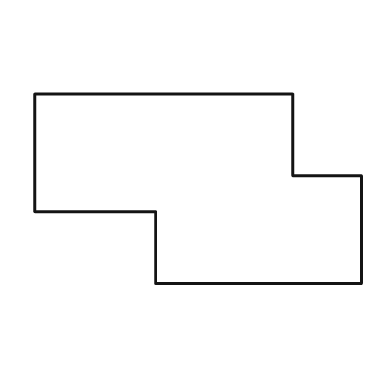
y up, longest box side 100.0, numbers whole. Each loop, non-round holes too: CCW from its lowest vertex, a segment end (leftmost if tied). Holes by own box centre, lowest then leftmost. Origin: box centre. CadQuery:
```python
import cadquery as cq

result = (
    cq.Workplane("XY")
    .moveTo(-13.0, -29.0)
    .lineTo(50.0, -29.0)
    .lineTo(50.0, 4.0)
    .lineTo(29.0, 4.0)
    .lineTo(29.0, 29.0)
    .lineTo(-50.0, 29.0)
    .lineTo(-50.0, -7.0)
    .lineTo(-13.0, -7.0)
    .close()
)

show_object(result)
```